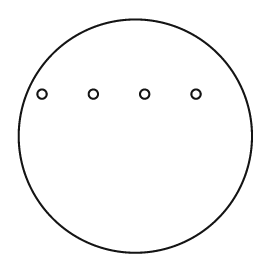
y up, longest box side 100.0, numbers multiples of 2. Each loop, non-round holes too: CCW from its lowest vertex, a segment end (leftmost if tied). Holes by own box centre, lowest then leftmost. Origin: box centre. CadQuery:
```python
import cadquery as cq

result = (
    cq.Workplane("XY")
    .moveTo(0.0, 0.0)
    .circle(50.0)
    .moveTo(-40.0, 18.0)
    .circle(2.0)
    .moveTo(-18.0, 18.0)
    .circle(2.0)
    .moveTo(4.0, 18.0)
    .circle(2.0)
    .moveTo(26.0, 18.0)
    .circle(2.0)
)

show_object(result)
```